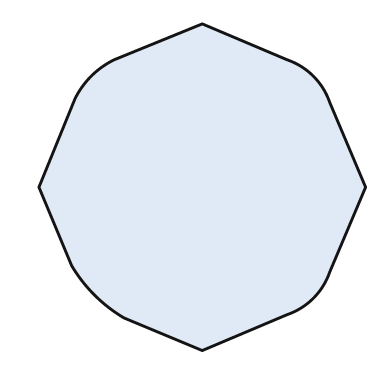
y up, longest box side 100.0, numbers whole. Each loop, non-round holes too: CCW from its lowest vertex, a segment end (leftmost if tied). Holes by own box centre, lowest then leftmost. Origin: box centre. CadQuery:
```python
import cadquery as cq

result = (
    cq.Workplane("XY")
    .moveTo(0.0, -50.0)
    .lineTo(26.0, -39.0)
    .threePointArc((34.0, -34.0), (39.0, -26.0))
    .lineTo(50.0, 0.0)
    .lineTo(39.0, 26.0)
    .threePointArc((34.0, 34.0), (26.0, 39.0))
    .lineTo(0.0, 50.0)
    .lineTo(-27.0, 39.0)
    .threePointArc((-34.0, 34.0), (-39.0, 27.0))
    .lineTo(-50.0, 0.0)
    .lineTo(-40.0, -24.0)
    .threePointArc((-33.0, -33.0), (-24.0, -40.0))
    .close()
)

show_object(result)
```